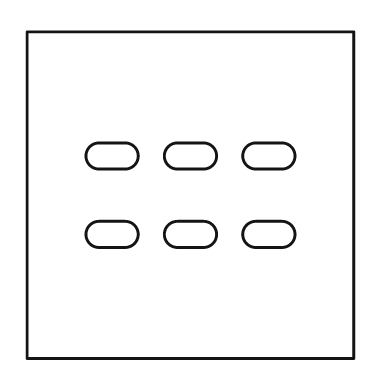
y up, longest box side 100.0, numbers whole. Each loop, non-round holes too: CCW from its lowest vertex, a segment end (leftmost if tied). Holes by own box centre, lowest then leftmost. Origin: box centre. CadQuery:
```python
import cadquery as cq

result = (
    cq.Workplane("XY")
    .moveTo(-50.0, -50.0)
    .lineTo(50.0, -50.0)
    .lineTo(50.0, 50.0)
    .lineTo(-50.0, 50.0)
    .close()
    .moveTo(-28.0, -16.0)
    .lineTo(-20.0, -16.0)
    .threePointArc((-16.0, -12.0), (-20.0, -8.0))
    .lineTo(-28.0, -8.0)
    .threePointArc((-32.0, -12.0), (-28.0, -16.0))
    .close()
    .moveTo(-4.0, -16.0)
    .lineTo(4.0, -16.0)
    .threePointArc((8.0, -12.0), (4.0, -8.0))
    .lineTo(-4.0, -8.0)
    .threePointArc((-8.0, -12.0), (-4.0, -16.0))
    .close()
    .moveTo(20.0, -16.0)
    .lineTo(28.0, -16.0)
    .threePointArc((32.0, -12.0), (28.0, -8.0))
    .lineTo(20.0, -8.0)
    .threePointArc((16.0, -12.0), (20.0, -16.0))
    .close()
    .moveTo(-28.0, 8.0)
    .lineTo(-20.0, 8.0)
    .threePointArc((-16.0, 12.0), (-20.0, 16.0))
    .lineTo(-28.0, 16.0)
    .threePointArc((-32.0, 12.0), (-28.0, 8.0))
    .close()
    .moveTo(-4.0, 8.0)
    .lineTo(4.0, 8.0)
    .threePointArc((8.0, 12.0), (4.0, 16.0))
    .lineTo(-4.0, 16.0)
    .threePointArc((-8.0, 12.0), (-4.0, 8.0))
    .close()
    .moveTo(20.0, 8.0)
    .lineTo(28.0, 8.0)
    .threePointArc((32.0, 12.0), (28.0, 16.0))
    .lineTo(20.0, 16.0)
    .threePointArc((16.0, 12.0), (20.0, 8.0))
    .close()
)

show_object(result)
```